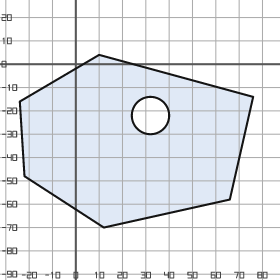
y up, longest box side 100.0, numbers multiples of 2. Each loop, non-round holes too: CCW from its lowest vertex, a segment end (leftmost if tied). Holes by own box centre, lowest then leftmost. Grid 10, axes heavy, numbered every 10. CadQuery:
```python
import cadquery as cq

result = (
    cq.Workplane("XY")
    .moveTo(12.0, -70.0)
    .lineTo(66.0, -58.0)
    .lineTo(76.0, -14.0)
    .lineTo(10.0, 4.0)
    .lineTo(-24.0, -16.0)
    .lineTo(-22.0, -48.0)
    .close()
    .moveTo(32.0, -22.0)
    .circle(8.0)
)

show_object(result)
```